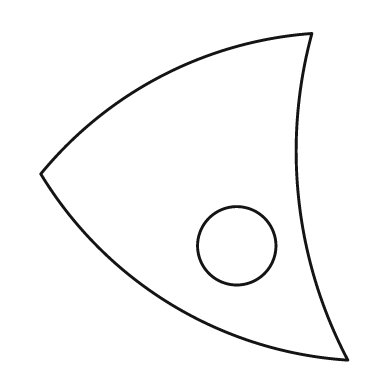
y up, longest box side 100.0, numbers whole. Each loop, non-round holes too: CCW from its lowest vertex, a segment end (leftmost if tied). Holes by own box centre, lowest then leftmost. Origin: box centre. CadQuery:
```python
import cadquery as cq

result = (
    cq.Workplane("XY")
    .moveTo(47.0, -50.0)
    .threePointArc((32.0, -1.0), (36.0, 50.0))
    .threePointArc((-10.0, 37.0), (-47.0, 7.0))
    .threePointArc((-7.0, -33.0), (47.0, -50.0))
    .close()
    .moveTo(13.0, -15.0)
    .circle(12.0)
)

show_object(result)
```